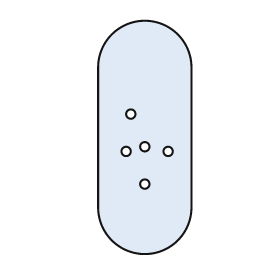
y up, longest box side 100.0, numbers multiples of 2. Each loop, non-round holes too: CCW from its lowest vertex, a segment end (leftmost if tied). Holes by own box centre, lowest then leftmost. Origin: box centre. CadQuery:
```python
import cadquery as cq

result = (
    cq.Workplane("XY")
    .moveTo(-20.0, -30.0)
    .threePointArc((0.0, -50.0), (20.0, -30.0))
    .lineTo(20.0, 30.0)
    .threePointArc((0.0, 50.0), (-20.0, 30.0))
    .close()
    .moveTo(0.0, -20.0)
    .circle(2.0)
    .moveTo(-8.0, -6.0)
    .circle(2.0)
    .moveTo(10.0, -6.0)
    .circle(2.0)
    .moveTo(0.0, -4.0)
    .circle(2.0)
    .moveTo(-6.0, 10.0)
    .circle(2.0)
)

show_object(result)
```